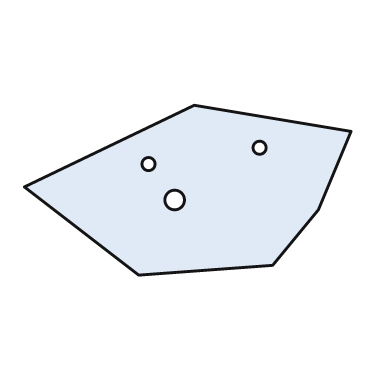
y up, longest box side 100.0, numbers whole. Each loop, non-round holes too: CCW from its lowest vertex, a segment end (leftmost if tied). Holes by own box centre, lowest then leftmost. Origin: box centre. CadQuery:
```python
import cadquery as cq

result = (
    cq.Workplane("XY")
    .moveTo(-15.0, -26.0)
    .lineTo(26.0, -23.0)
    .lineTo(40.0, -6.0)
    .lineTo(50.0, 18.0)
    .lineTo(2.0, 26.0)
    .lineTo(-50.0, 1.0)
    .close()
    .moveTo(-4.0, -3.0)
    .circle(3.0)
    .moveTo(-12.0, 8.0)
    .circle(2.0)
    .moveTo(22.0, 13.0)
    .circle(2.0)
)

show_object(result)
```